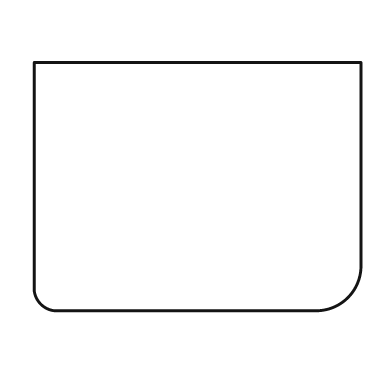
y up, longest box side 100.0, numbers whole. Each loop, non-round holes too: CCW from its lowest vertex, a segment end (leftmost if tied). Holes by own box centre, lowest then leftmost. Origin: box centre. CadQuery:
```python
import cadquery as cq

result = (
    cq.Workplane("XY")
    .moveTo(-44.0, -38.0)
    .lineTo(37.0, -38.0)
    .threePointArc((46.0, -34.0), (50.0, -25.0))
    .lineTo(50.0, 38.0)
    .lineTo(-50.0, 38.0)
    .lineTo(-50.0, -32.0)
    .threePointArc((-48.0, -36.0), (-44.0, -38.0))
    .close()
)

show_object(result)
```